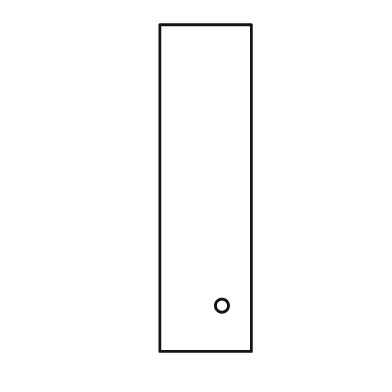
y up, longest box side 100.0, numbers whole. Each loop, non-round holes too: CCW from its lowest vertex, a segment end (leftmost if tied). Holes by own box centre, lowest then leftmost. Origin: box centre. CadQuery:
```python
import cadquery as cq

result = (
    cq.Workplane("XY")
    .moveTo(-14.0, -50.0)
    .lineTo(14.0, -50.0)
    .lineTo(14.0, 50.0)
    .lineTo(-14.0, 50.0)
    .close()
    .moveTo(5.0, -36.0)
    .circle(2.0)
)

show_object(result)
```